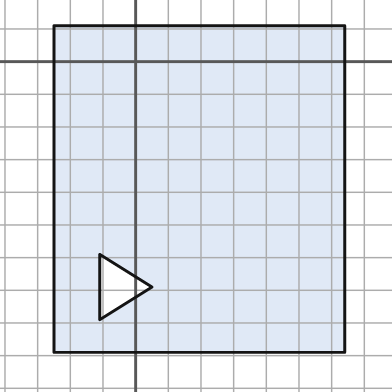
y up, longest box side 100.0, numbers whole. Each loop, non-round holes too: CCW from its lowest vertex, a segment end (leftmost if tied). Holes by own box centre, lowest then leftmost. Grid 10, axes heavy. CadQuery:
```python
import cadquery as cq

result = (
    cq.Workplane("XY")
    .moveTo(-25.0, -89.0)
    .lineTo(64.0, -89.0)
    .lineTo(64.0, 11.0)
    .lineTo(-25.0, 11.0)
    .close()
    .moveTo(-11.0, -79.0)
    .lineTo(5.0, -69.0)
    .lineTo(-11.0, -59.0)
    .close()
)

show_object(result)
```